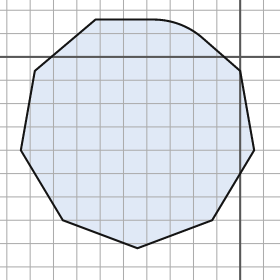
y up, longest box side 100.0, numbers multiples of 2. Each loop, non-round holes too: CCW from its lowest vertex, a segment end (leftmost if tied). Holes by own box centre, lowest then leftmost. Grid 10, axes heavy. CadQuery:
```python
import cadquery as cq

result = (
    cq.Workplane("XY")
    .moveTo(-44.0, -82.0)
    .lineTo(-12.0, -70.0)
    .lineTo(6.0, -40.0)
    .lineTo(0.0, -6.0)
    .lineTo(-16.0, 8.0)
    .threePointArc((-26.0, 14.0), (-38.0, 16.0))
    .lineTo(-62.0, 16.0)
    .lineTo(-88.0, -6.0)
    .lineTo(-94.0, -40.0)
    .lineTo(-76.0, -70.0)
    .close()
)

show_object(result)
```